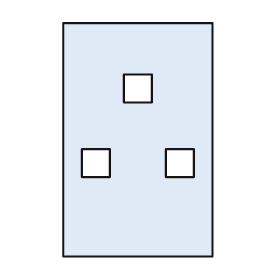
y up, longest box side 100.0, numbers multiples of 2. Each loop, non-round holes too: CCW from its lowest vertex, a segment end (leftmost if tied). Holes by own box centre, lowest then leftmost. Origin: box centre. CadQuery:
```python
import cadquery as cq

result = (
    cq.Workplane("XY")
    .moveTo(-32.0, -50.0)
    .lineTo(32.0, -50.0)
    .lineTo(32.0, 50.0)
    .lineTo(-32.0, 50.0)
    .close()
    .moveTo(-24.0, -16.0)
    .lineTo(-12.0, -16.0)
    .lineTo(-12.0, -4.0)
    .lineTo(-24.0, -4.0)
    .close()
    .moveTo(12.0, -16.0)
    .lineTo(24.0, -16.0)
    .lineTo(24.0, -4.0)
    .lineTo(12.0, -4.0)
    .close()
    .moveTo(-6.0, 16.0)
    .lineTo(6.0, 16.0)
    .lineTo(6.0, 28.0)
    .lineTo(-6.0, 28.0)
    .close()
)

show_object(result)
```